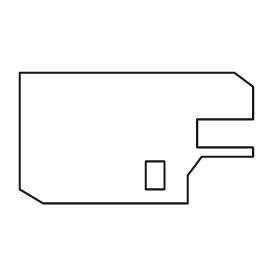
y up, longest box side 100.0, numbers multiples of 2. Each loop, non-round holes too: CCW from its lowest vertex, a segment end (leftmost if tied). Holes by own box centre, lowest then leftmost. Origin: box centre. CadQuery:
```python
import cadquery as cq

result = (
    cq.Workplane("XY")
    .moveTo(-40.0, -28.0)
    .lineTo(22.0, -28.0)
    .lineTo(22.0, -16.0)
    .lineTo(28.0, -8.0)
    .lineTo(50.0, -8.0)
    .lineTo(50.0, -4.0)
    .lineTo(26.0, -4.0)
    .lineTo(26.0, 8.0)
    .lineTo(50.0, 8.0)
    .lineTo(50.0, 22.0)
    .lineTo(42.0, 28.0)
    .lineTo(-50.0, 28.0)
    .lineTo(-50.0, -22.0)
    .close()
    .moveTo(4.0, -22.0)
    .lineTo(12.0, -22.0)
    .lineTo(12.0, -10.0)
    .lineTo(4.0, -10.0)
    .close()
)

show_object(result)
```